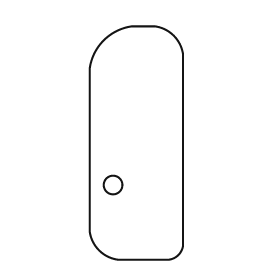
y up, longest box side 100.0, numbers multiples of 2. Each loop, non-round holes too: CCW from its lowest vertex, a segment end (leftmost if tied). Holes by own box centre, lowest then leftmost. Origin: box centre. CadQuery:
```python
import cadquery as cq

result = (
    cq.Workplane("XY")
    .moveTo(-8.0, -50.0)
    .lineTo(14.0, -50.0)
    .threePointArc((18.0, -48.0), (20.0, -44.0))
    .lineTo(20.0, 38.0)
    .threePointArc((16.0, 46.0), (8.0, 50.0))
    .lineTo(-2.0, 50.0)
    .threePointArc((-14.0, 44.0), (-20.0, 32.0))
    .lineTo(-20.0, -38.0)
    .threePointArc((-16.0, -46.0), (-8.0, -50.0))
    .close()
    .moveTo(-10.0, -18.0)
    .circle(4.0)
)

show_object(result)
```